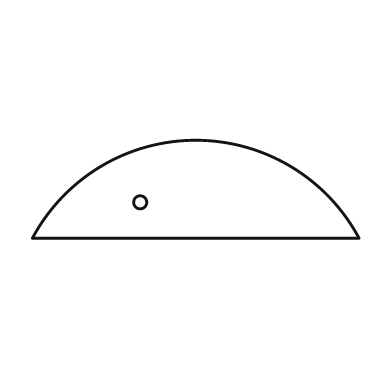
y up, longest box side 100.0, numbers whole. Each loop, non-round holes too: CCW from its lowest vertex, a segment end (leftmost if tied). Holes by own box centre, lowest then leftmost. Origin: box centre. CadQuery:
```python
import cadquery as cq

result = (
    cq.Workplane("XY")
    .moveTo(-50.0, -15.0)
    .lineTo(50.0, -15.0)
    .threePointArc((0.0, 15.0), (-50.0, -15.0))
    .close()
    .moveTo(-17.0, -4.0)
    .circle(2.0)
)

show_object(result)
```